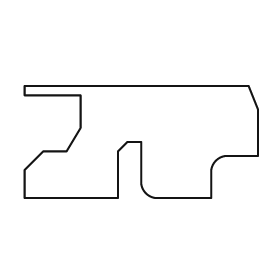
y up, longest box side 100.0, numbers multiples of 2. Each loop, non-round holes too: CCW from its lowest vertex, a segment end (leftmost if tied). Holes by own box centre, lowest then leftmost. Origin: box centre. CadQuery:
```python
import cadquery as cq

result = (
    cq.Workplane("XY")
    .moveTo(-50.0, -24.0)
    .lineTo(-10.0, -24.0)
    .lineTo(-10.0, -4.0)
    .lineTo(-6.0, 0.0)
    .lineTo(0.0, 0.0)
    .lineTo(0.0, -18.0)
    .threePointArc((2.0, -22.0), (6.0, -24.0))
    .lineTo(30.0, -24.0)
    .lineTo(30.0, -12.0)
    .threePointArc((32.0, -8.0), (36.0, -6.0))
    .lineTo(50.0, -6.0)
    .lineTo(50.0, 14.0)
    .lineTo(46.0, 24.0)
    .lineTo(-50.0, 24.0)
    .lineTo(-50.0, 20.0)
    .lineTo(-26.0, 20.0)
    .lineTo(-26.0, 6.0)
    .lineTo(-32.0, -4.0)
    .lineTo(-42.0, -4.0)
    .lineTo(-50.0, -12.0)
    .close()
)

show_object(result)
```